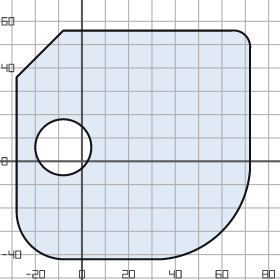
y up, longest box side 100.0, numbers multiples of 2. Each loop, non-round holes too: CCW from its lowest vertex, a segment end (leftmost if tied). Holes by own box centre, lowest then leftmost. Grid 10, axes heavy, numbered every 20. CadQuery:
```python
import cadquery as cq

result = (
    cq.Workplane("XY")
    .moveTo(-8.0, -42.0)
    .lineTo(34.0, -42.0)
    .threePointArc((60.0, -30.0), (72.0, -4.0))
    .lineTo(72.0, 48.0)
    .threePointArc((70.0, 54.0), (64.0, 56.0))
    .lineTo(-8.0, 56.0)
    .lineTo(-28.0, 36.0)
    .lineTo(-28.0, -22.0)
    .threePointArc((-22.0, -36.0), (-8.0, -42.0))
    .close()
    .moveTo(-8.0, 6.0)
    .circle(12.0)
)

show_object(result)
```